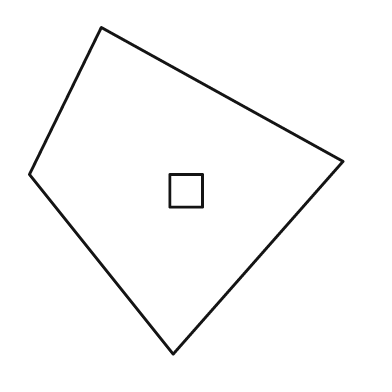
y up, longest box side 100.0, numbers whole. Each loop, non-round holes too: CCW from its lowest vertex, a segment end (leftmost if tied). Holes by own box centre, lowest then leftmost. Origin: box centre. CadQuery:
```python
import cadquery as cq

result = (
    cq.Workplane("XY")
    .moveTo(-4.0, -50.0)
    .lineTo(48.0, 9.0)
    .lineTo(-26.0, 50.0)
    .lineTo(-48.0, 5.0)
    .close()
    .moveTo(-5.0, -5.0)
    .lineTo(5.0, -5.0)
    .lineTo(5.0, 5.0)
    .lineTo(-5.0, 5.0)
    .close()
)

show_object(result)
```